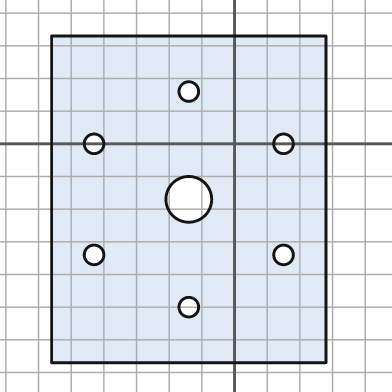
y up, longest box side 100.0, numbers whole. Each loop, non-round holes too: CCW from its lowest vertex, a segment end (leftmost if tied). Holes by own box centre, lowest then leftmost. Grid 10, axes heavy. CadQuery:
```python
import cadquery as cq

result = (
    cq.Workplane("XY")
    .moveTo(-56.0, -67.0)
    .lineTo(28.0, -67.0)
    .lineTo(28.0, 33.0)
    .lineTo(-56.0, 33.0)
    .close()
    .moveTo(-14.0, -50.0)
    .circle(3.0)
    .moveTo(-43.0, -34.0)
    .circle(3.0)
    .moveTo(15.0, -34.0)
    .circle(3.0)
    .moveTo(-14.0, -17.0)
    .circle(7.0)
    .moveTo(-43.0, 0.0)
    .circle(3.0)
    .moveTo(15.0, 0.0)
    .circle(3.0)
    .moveTo(-14.0, 16.0)
    .circle(3.0)
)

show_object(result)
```